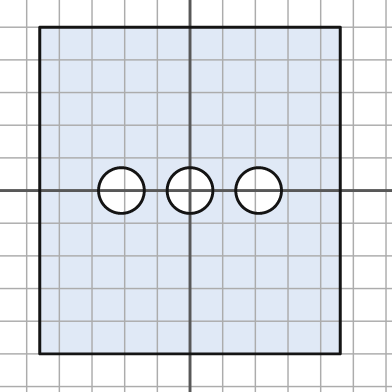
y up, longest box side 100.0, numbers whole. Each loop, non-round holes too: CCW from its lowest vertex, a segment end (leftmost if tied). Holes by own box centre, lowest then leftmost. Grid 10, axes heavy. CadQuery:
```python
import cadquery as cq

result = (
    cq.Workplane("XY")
    .moveTo(-46.0, -50.0)
    .lineTo(46.0, -50.0)
    .lineTo(46.0, 50.0)
    .lineTo(-46.0, 50.0)
    .close()
    .moveTo(-21.0, 0.0)
    .circle(7.0)
    .moveTo(0.0, 0.0)
    .circle(7.0)
    .moveTo(21.0, 0.0)
    .circle(7.0)
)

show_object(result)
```